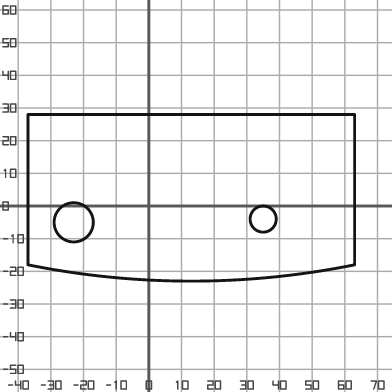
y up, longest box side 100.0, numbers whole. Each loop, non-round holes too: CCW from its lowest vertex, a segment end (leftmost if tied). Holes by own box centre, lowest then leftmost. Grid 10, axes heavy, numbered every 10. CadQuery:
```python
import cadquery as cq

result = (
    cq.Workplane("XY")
    .moveTo(-37.0, -18.0)
    .threePointArc((13.0, -23.0), (63.0, -18.0))
    .lineTo(63.0, 28.0)
    .lineTo(-37.0, 28.0)
    .close()
    .moveTo(-23.0, -5.0)
    .circle(6.0)
    .moveTo(35.0, -4.0)
    .circle(4.0)
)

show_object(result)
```